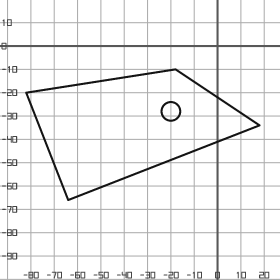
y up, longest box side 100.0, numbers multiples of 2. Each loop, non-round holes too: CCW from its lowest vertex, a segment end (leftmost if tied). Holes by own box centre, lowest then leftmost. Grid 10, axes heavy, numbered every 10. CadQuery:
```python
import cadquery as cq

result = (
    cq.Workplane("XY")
    .moveTo(-64.0, -66.0)
    .lineTo(18.0, -34.0)
    .lineTo(-18.0, -10.0)
    .lineTo(-82.0, -20.0)
    .close()
    .moveTo(-20.0, -28.0)
    .circle(4.0)
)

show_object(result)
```